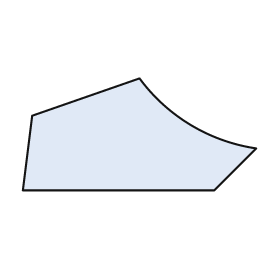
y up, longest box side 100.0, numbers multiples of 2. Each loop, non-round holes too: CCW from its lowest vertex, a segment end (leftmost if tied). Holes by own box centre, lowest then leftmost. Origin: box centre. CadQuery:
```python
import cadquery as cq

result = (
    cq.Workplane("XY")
    .moveTo(-50.0, -24.0)
    .lineTo(32.0, -24.0)
    .lineTo(50.0, -6.0)
    .threePointArc((22.0, 4.0), (0.0, 24.0))
    .lineTo(-46.0, 8.0)
    .close()
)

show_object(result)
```